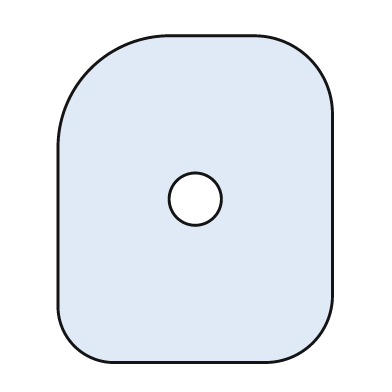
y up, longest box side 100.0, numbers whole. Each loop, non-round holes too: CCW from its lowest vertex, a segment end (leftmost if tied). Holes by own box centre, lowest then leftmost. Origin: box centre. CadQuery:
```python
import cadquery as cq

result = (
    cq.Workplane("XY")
    .moveTo(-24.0, -50.0)
    .lineTo(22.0, -50.0)
    .threePointArc((36.0, -44.0), (42.0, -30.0))
    .lineTo(42.0, 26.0)
    .threePointArc((35.0, 43.0), (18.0, 50.0))
    .lineTo(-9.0, 50.0)
    .threePointArc((-32.0, 40.0), (-42.0, 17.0))
    .lineTo(-42.0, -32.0)
    .threePointArc((-37.0, -45.0), (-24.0, -50.0))
    .close()
    .moveTo(0.0, 0.0)
    .circle(8.0)
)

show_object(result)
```